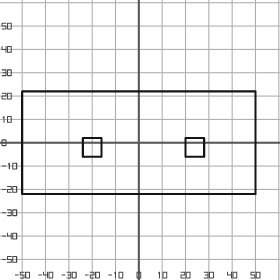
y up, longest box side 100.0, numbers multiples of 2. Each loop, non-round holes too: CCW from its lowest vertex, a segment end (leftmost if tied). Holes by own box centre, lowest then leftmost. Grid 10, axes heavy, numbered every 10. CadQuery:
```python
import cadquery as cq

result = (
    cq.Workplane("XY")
    .moveTo(-50.0, -22.0)
    .lineTo(50.0, -22.0)
    .lineTo(50.0, 22.0)
    .lineTo(-50.0, 22.0)
    .close()
    .moveTo(-24.0, -6.0)
    .lineTo(-16.0, -6.0)
    .lineTo(-16.0, 2.0)
    .lineTo(-24.0, 2.0)
    .close()
    .moveTo(20.0, -6.0)
    .lineTo(28.0, -6.0)
    .lineTo(28.0, 2.0)
    .lineTo(20.0, 2.0)
    .close()
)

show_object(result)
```